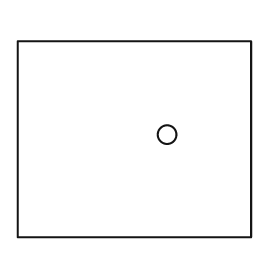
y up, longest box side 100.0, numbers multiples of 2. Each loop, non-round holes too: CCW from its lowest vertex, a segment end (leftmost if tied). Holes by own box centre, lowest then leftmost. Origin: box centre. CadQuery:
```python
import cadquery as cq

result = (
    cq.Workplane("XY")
    .moveTo(-50.0, -42.0)
    .lineTo(50.0, -42.0)
    .lineTo(50.0, 42.0)
    .lineTo(-50.0, 42.0)
    .close()
    .moveTo(14.0, 2.0)
    .circle(4.0)
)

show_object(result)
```